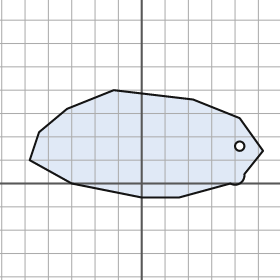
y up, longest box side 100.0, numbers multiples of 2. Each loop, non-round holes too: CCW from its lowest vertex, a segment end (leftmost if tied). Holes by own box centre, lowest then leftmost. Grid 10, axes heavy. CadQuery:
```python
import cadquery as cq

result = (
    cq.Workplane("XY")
    .moveTo(0.0, -6.0)
    .lineTo(16.0, -6.0)
    .lineTo(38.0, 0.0)
    .threePointArc((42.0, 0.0), (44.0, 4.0))
    .lineTo(52.0, 14.0)
    .lineTo(42.0, 28.0)
    .lineTo(22.0, 36.0)
    .lineTo(-12.0, 40.0)
    .lineTo(-32.0, 32.0)
    .lineTo(-44.0, 22.0)
    .lineTo(-48.0, 10.0)
    .lineTo(-30.0, 0.0)
    .close()
    .moveTo(42.0, 16.0)
    .circle(2.0)
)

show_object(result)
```